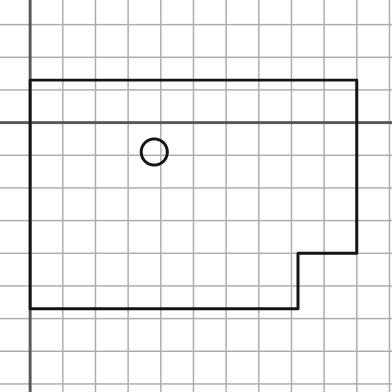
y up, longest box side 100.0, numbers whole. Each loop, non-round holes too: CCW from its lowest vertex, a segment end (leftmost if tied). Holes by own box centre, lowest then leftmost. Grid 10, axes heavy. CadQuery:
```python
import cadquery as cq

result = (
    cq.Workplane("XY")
    .moveTo(0.0, -57.0)
    .lineTo(82.0, -57.0)
    .lineTo(82.0, -40.0)
    .lineTo(100.0, -40.0)
    .lineTo(100.0, 13.0)
    .lineTo(0.0, 13.0)
    .close()
    .moveTo(38.0, -9.0)
    .circle(4.0)
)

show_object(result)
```